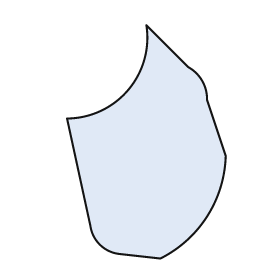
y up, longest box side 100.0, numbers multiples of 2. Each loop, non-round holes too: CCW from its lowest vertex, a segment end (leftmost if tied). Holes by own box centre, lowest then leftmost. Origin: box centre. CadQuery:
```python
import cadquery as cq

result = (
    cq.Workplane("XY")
    .moveTo(6.0, -50.0)
    .threePointArc((26.0, -32.0), (34.0, -6.0))
    .lineTo(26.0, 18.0)
    .threePointArc((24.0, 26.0), (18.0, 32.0))
    .lineTo(0.0, 50.0)
    .threePointArc((-8.0, 22.0), (-34.0, 10.0))
    .lineTo(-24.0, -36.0)
    .threePointArc((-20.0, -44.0), (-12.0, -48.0))
    .close()
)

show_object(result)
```